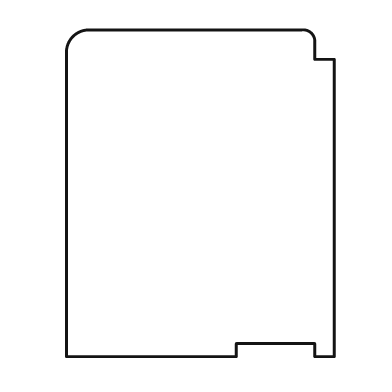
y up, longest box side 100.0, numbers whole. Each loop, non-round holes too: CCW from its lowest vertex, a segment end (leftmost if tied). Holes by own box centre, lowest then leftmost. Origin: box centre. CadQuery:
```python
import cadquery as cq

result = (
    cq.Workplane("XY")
    .moveTo(-41.0, -50.0)
    .lineTo(11.0, -50.0)
    .lineTo(11.0, -46.0)
    .lineTo(35.0, -46.0)
    .lineTo(35.0, -50.0)
    .lineTo(41.0, -50.0)
    .lineTo(41.0, 41.0)
    .lineTo(35.0, 41.0)
    .lineTo(35.0, 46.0)
    .threePointArc((34.0, 49.0), (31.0, 50.0))
    .lineTo(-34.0, 50.0)
    .threePointArc((-39.0, 48.0), (-41.0, 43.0))
    .close()
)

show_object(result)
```